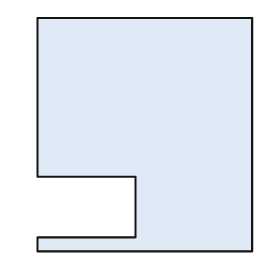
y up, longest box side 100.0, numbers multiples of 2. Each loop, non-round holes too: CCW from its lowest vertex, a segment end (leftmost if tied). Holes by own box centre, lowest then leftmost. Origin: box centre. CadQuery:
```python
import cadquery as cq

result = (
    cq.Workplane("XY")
    .moveTo(-46.0, -50.0)
    .lineTo(46.0, -50.0)
    .lineTo(46.0, 50.0)
    .lineTo(-46.0, 50.0)
    .lineTo(-46.0, -18.0)
    .lineTo(-4.0, -18.0)
    .lineTo(-4.0, -44.0)
    .lineTo(-46.0, -44.0)
    .close()
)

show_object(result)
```